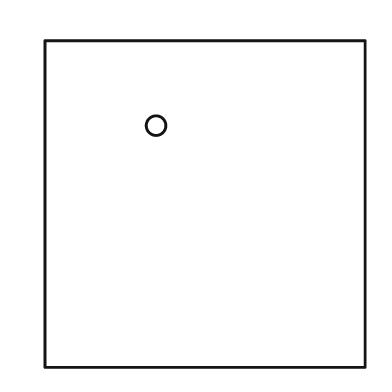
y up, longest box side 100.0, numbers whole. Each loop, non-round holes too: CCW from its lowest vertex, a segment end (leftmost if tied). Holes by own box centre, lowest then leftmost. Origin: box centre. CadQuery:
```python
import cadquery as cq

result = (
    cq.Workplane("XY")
    .moveTo(-49.0, -50.0)
    .lineTo(49.0, -50.0)
    .lineTo(49.0, 50.0)
    .lineTo(-49.0, 50.0)
    .close()
    .moveTo(-15.0, 24.0)
    .circle(3.0)
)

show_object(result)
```